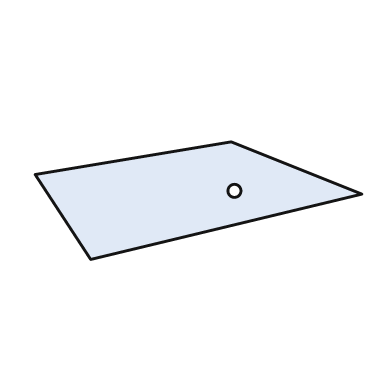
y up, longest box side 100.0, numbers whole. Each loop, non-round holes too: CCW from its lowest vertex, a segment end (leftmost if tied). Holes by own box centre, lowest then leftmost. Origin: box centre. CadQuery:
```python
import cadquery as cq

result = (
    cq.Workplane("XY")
    .moveTo(-33.0, -18.0)
    .lineTo(50.0, 2.0)
    .lineTo(10.0, 18.0)
    .lineTo(-50.0, 8.0)
    .close()
    .moveTo(11.0, 3.0)
    .circle(2.0)
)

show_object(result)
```